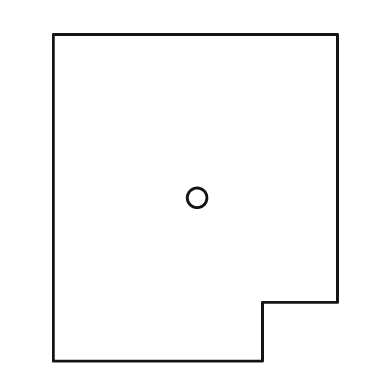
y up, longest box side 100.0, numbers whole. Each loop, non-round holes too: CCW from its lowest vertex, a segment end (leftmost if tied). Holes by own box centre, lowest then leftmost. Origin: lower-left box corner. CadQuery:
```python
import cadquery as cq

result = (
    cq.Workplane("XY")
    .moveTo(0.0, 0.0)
    .lineTo(64.0, 0.0)
    .lineTo(64.0, 18.0)
    .lineTo(87.0, 18.0)
    .lineTo(87.0, 100.0)
    .lineTo(0.0, 100.0)
    .close()
    .moveTo(44.0, 50.0)
    .circle(3.0)
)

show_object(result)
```